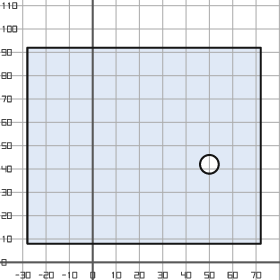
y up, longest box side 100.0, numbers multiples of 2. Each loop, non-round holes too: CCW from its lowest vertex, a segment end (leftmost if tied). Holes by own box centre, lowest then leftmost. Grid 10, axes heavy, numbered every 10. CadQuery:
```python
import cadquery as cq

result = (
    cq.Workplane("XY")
    .moveTo(-28.0, 8.0)
    .lineTo(72.0, 8.0)
    .lineTo(72.0, 92.0)
    .lineTo(-28.0, 92.0)
    .close()
    .moveTo(50.0, 42.0)
    .circle(4.0)
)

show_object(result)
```